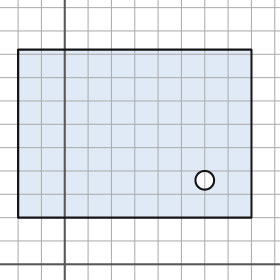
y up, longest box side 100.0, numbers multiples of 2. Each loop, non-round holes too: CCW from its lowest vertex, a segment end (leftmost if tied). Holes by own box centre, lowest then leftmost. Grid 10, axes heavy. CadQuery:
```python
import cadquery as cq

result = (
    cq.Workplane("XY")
    .moveTo(-20.0, 20.0)
    .lineTo(80.0, 20.0)
    .lineTo(80.0, 92.0)
    .lineTo(-20.0, 92.0)
    .close()
    .moveTo(60.0, 36.0)
    .circle(4.0)
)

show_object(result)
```